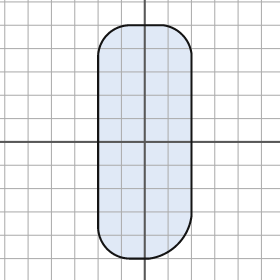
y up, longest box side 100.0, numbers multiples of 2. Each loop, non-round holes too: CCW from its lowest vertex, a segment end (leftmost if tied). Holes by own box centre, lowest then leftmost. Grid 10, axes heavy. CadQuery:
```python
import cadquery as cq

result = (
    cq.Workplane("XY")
    .moveTo(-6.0, -50.0)
    .lineTo(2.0, -50.0)
    .threePointArc((14.0, -44.0), (20.0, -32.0))
    .lineTo(20.0, 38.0)
    .threePointArc((16.0, 46.0), (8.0, 50.0))
    .lineTo(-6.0, 50.0)
    .threePointArc((-16.0, 46.0), (-20.0, 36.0))
    .lineTo(-20.0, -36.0)
    .threePointArc((-16.0, -46.0), (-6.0, -50.0))
    .close()
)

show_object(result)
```